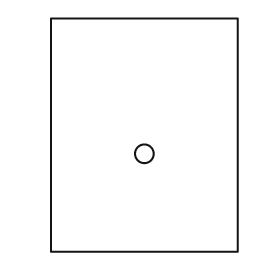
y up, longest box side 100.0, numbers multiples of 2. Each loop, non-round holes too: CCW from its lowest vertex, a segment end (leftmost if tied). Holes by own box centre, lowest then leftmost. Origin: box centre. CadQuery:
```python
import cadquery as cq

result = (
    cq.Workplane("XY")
    .moveTo(-40.0, -50.0)
    .lineTo(40.0, -50.0)
    .lineTo(40.0, 50.0)
    .lineTo(-40.0, 50.0)
    .close()
    .moveTo(0.0, -8.0)
    .circle(4.0)
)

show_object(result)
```